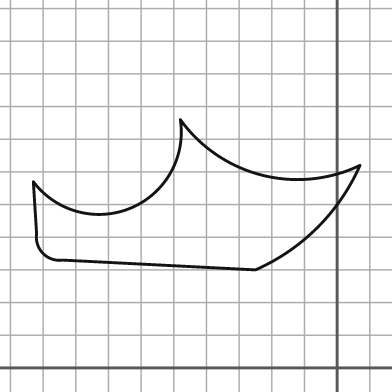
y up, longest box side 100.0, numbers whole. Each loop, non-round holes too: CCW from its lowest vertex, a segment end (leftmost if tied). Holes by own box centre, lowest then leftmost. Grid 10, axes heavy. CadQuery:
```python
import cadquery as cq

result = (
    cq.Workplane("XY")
    .moveTo(-25.0, 30.0)
    .threePointArc((-6.0, 43.0), (7.0, 62.0))
    .threePointArc((-23.0, 59.0), (-48.0, 76.0))
    .threePointArc((-63.0, 49.0), (-93.0, 57.0))
    .lineTo(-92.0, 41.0)
    .threePointArc((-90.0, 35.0), (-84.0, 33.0))
    .close()
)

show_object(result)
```